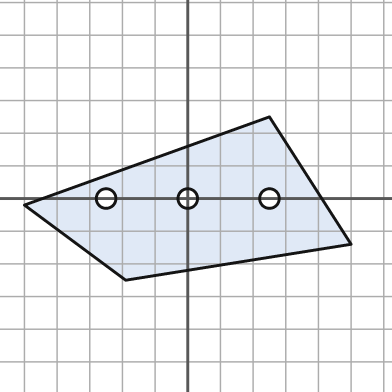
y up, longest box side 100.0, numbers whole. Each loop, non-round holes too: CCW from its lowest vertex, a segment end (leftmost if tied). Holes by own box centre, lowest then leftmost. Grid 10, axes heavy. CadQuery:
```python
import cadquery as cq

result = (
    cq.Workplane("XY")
    .moveTo(-19.0, -25.0)
    .lineTo(50.0, -14.0)
    .lineTo(25.0, 25.0)
    .lineTo(-50.0, -2.0)
    .close()
    .moveTo(-25.0, 0.0)
    .circle(3.0)
    .moveTo(0.0, 0.0)
    .circle(3.0)
    .moveTo(25.0, 0.0)
    .circle(3.0)
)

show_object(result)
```